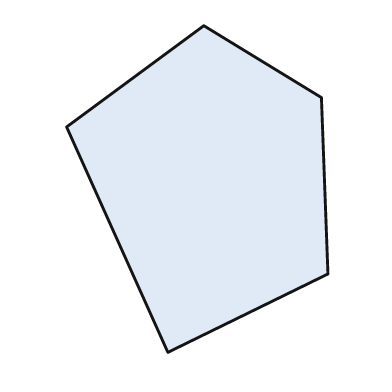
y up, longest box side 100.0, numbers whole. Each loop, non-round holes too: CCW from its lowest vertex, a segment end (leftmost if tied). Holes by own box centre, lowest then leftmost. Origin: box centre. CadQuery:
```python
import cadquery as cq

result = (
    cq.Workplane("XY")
    .moveTo(-9.0, -50.0)
    .lineTo(40.0, -26.0)
    .lineTo(38.0, 28.0)
    .lineTo(2.0, 50.0)
    .lineTo(-40.0, 19.0)
    .close()
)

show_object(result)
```